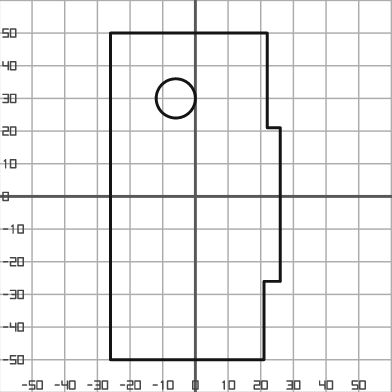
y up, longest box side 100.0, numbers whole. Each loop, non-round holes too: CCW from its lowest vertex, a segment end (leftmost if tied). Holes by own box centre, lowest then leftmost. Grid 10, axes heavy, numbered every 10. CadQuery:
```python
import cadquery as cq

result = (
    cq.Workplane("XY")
    .moveTo(-26.0, -50.0)
    .lineTo(21.0, -50.0)
    .lineTo(21.0, -26.0)
    .lineTo(26.0, -26.0)
    .lineTo(26.0, 21.0)
    .lineTo(22.0, 21.0)
    .lineTo(22.0, 50.0)
    .lineTo(-26.0, 50.0)
    .close()
    .moveTo(-6.0, 30.0)
    .circle(6.0)
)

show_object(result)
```